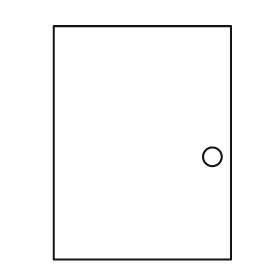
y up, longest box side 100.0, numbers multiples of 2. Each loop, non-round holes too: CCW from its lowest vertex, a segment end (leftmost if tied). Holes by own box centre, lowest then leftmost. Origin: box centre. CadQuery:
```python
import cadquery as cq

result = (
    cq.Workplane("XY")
    .moveTo(-38.0, -50.0)
    .lineTo(38.0, -50.0)
    .lineTo(38.0, 50.0)
    .lineTo(-38.0, 50.0)
    .close()
    .moveTo(30.0, -6.0)
    .circle(4.0)
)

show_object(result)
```